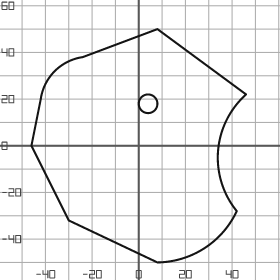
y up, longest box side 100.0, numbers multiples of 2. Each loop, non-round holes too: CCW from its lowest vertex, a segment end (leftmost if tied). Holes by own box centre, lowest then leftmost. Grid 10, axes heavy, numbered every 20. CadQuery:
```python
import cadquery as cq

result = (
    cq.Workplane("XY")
    .moveTo(8.0, -50.0)
    .threePointArc((28.0, -44.0), (42.0, -28.0))
    .threePointArc((34.0, -2.0), (46.0, 22.0))
    .lineTo(8.0, 50.0)
    .lineTo(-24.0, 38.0)
    .threePointArc((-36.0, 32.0), (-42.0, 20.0))
    .lineTo(-46.0, 0.0)
    .lineTo(-30.0, -32.0)
    .close()
    .moveTo(4.0, 18.0)
    .circle(4.0)
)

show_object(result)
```